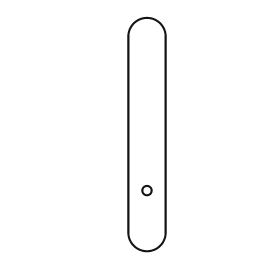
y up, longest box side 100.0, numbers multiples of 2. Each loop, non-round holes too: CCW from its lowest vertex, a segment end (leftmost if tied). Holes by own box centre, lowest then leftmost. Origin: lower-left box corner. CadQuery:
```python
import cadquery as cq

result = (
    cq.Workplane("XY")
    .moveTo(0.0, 8.0)
    .threePointArc((8.0, 0.0), (16.0, 8.0))
    .lineTo(16.0, 92.0)
    .threePointArc((8.0, 100.0), (0.0, 92.0))
    .close()
    .moveTo(8.0, 26.0)
    .circle(2.0)
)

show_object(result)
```